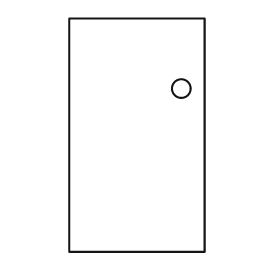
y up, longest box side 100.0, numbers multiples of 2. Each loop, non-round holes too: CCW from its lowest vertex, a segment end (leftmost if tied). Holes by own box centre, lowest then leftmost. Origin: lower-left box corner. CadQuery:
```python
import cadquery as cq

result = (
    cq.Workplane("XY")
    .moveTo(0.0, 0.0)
    .lineTo(58.0, 0.0)
    .lineTo(58.0, 100.0)
    .lineTo(0.0, 100.0)
    .close()
    .moveTo(48.0, 70.0)
    .circle(4.0)
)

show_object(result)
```